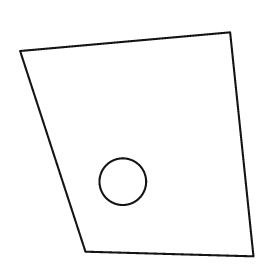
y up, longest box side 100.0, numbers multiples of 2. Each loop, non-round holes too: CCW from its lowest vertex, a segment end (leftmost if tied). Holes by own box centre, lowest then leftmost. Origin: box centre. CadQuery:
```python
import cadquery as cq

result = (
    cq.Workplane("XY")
    .moveTo(50.0, -48.0)
    .lineTo(40.0, 48.0)
    .lineTo(-50.0, 40.0)
    .lineTo(-22.0, -46.0)
    .close()
    .moveTo(-6.0, -16.0)
    .circle(10.0)
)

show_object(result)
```